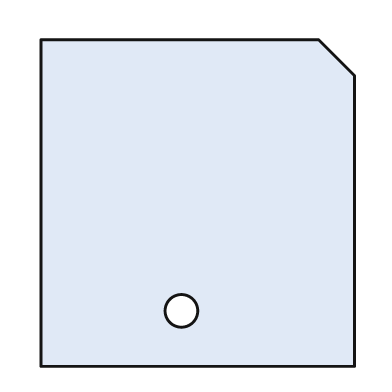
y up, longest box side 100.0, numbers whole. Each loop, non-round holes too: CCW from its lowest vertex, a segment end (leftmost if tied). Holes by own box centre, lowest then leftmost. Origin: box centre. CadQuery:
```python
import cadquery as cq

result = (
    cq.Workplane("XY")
    .moveTo(-48.0, -50.0)
    .lineTo(48.0, -50.0)
    .lineTo(48.0, 39.0)
    .lineTo(37.0, 50.0)
    .lineTo(-48.0, 50.0)
    .close()
    .moveTo(-5.0, -33.0)
    .circle(5.0)
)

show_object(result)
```